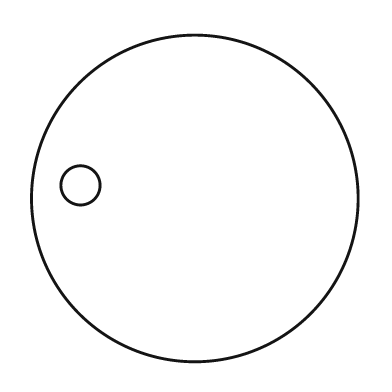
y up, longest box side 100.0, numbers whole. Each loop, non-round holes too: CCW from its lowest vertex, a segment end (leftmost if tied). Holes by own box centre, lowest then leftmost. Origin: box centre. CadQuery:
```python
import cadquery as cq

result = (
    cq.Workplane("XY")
    .moveTo(0.0, 0.0)
    .circle(50.0)
    .moveTo(-35.0, 4.0)
    .circle(6.0)
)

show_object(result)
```